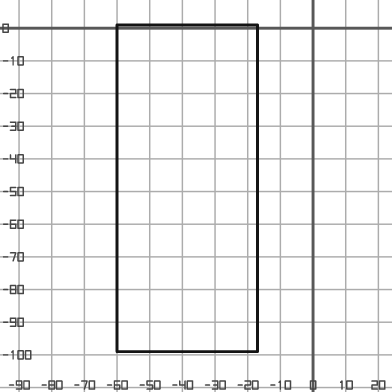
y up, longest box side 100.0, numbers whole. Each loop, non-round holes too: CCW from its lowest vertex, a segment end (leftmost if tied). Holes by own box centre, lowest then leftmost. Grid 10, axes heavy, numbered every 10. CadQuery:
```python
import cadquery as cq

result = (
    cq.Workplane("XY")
    .moveTo(-60.0, -99.0)
    .lineTo(-17.0, -99.0)
    .lineTo(-17.0, 1.0)
    .lineTo(-60.0, 1.0)
    .close()
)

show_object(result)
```